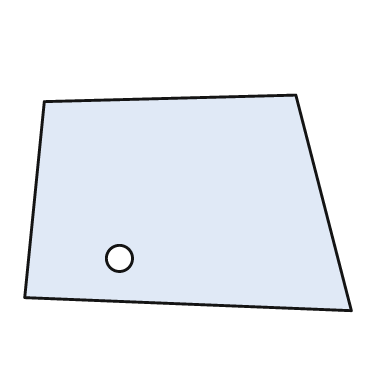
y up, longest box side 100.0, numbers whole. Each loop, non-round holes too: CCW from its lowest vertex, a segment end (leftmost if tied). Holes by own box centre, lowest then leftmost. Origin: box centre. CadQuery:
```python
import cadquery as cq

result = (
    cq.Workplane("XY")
    .moveTo(50.0, -33.0)
    .lineTo(33.0, 33.0)
    .lineTo(-44.0, 31.0)
    .lineTo(-50.0, -29.0)
    .close()
    .moveTo(-21.0, -17.0)
    .circle(4.0)
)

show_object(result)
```